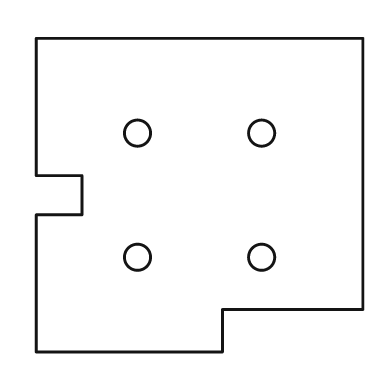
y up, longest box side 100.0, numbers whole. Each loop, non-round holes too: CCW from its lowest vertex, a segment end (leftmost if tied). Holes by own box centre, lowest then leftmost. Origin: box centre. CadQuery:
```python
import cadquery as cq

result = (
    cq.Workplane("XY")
    .moveTo(-50.0, -48.0)
    .lineTo(7.0, -48.0)
    .lineTo(7.0, -35.0)
    .lineTo(50.0, -35.0)
    .lineTo(50.0, 48.0)
    .lineTo(-50.0, 48.0)
    .lineTo(-50.0, 6.0)
    .lineTo(-36.0, 6.0)
    .lineTo(-36.0, -6.0)
    .lineTo(-50.0, -6.0)
    .close()
    .moveTo(-19.0, -19.0)
    .circle(4.0)
    .moveTo(19.0, -19.0)
    .circle(4.0)
    .moveTo(-19.0, 19.0)
    .circle(4.0)
    .moveTo(19.0, 19.0)
    .circle(4.0)
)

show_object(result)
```